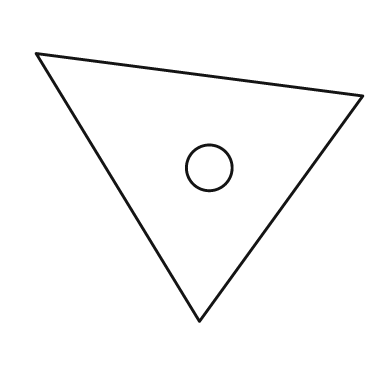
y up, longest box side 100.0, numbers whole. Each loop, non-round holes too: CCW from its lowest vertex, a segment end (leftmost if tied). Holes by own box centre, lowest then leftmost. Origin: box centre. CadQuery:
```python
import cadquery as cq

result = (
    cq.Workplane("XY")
    .moveTo(0.0, -41.0)
    .lineTo(50.0, 28.0)
    .lineTo(-50.0, 41.0)
    .close()
    .moveTo(3.0, 6.0)
    .circle(7.0)
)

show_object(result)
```